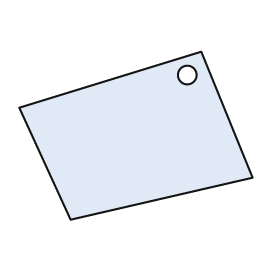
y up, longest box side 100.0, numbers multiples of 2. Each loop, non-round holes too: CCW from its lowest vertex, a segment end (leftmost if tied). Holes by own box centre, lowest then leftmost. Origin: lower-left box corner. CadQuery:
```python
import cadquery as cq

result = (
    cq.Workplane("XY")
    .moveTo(22.0, 0.0)
    .lineTo(100.0, 18.0)
    .lineTo(78.0, 72.0)
    .lineTo(0.0, 48.0)
    .close()
    .moveTo(72.0, 62.0)
    .circle(4.0)
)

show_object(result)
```